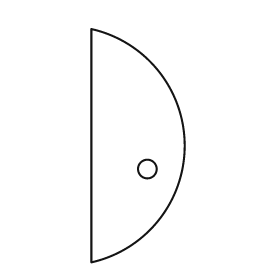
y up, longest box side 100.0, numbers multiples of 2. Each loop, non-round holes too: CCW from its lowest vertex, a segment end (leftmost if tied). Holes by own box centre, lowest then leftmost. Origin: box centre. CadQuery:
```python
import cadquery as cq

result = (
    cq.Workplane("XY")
    .moveTo(-20.0, -50.0)
    .threePointArc((20.0, 0.0), (-20.0, 50.0))
    .close()
    .moveTo(4.0, -10.0)
    .circle(4.0)
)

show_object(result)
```